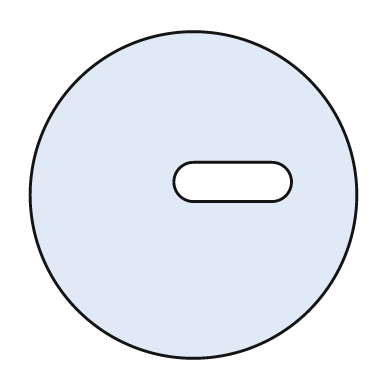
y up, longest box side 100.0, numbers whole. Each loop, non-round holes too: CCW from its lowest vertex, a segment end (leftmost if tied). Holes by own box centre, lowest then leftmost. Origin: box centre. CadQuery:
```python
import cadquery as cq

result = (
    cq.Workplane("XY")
    .moveTo(0.0, 0.0)
    .circle(50.0)
    .moveTo(0.0, -2.0)
    .lineTo(24.0, -2.0)
    .threePointArc((30.0, 4.0), (24.0, 10.0))
    .lineTo(0.0, 10.0)
    .threePointArc((-6.0, 4.0), (0.0, -2.0))
    .close()
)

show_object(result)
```